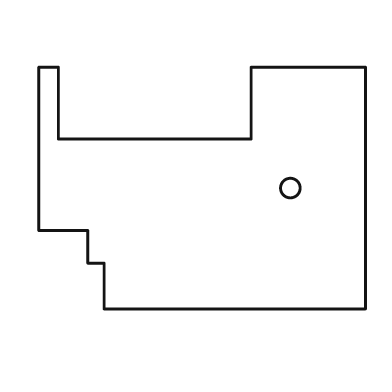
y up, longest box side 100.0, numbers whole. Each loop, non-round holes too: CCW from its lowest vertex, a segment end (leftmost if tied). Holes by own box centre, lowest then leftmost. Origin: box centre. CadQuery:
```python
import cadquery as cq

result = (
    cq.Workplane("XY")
    .moveTo(-30.0, -37.0)
    .lineTo(50.0, -37.0)
    .lineTo(50.0, 37.0)
    .lineTo(15.0, 37.0)
    .lineTo(15.0, 15.0)
    .lineTo(-44.0, 15.0)
    .lineTo(-44.0, 37.0)
    .lineTo(-50.0, 37.0)
    .lineTo(-50.0, -13.0)
    .lineTo(-35.0, -13.0)
    .lineTo(-35.0, -23.0)
    .lineTo(-30.0, -23.0)
    .close()
    .moveTo(27.0, 0.0)
    .circle(3.0)
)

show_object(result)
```